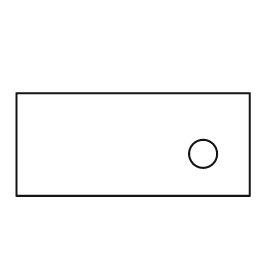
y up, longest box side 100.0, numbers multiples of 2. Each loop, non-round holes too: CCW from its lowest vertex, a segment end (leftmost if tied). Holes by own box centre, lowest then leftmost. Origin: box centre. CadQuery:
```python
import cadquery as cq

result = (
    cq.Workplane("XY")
    .moveTo(-50.0, -22.0)
    .lineTo(50.0, -22.0)
    .lineTo(50.0, 22.0)
    .lineTo(-50.0, 22.0)
    .close()
    .moveTo(30.0, -4.0)
    .circle(6.0)
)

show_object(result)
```